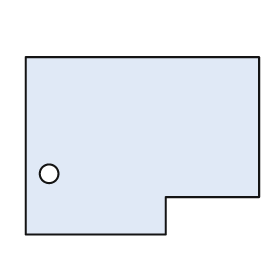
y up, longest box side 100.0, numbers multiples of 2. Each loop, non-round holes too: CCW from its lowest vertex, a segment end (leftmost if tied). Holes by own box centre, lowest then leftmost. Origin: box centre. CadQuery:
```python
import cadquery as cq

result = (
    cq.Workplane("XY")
    .moveTo(-50.0, -38.0)
    .lineTo(10.0, -38.0)
    .lineTo(10.0, -22.0)
    .lineTo(50.0, -22.0)
    .lineTo(50.0, 38.0)
    .lineTo(-50.0, 38.0)
    .close()
    .moveTo(-40.0, -12.0)
    .circle(4.0)
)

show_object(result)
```